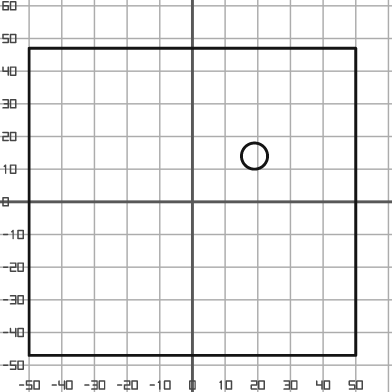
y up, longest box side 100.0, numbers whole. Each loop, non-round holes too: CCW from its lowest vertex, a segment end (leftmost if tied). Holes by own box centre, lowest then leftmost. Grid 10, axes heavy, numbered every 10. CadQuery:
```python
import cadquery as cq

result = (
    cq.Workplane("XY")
    .moveTo(-50.0, -47.0)
    .lineTo(50.0, -47.0)
    .lineTo(50.0, 47.0)
    .lineTo(-50.0, 47.0)
    .close()
    .moveTo(19.0, 14.0)
    .circle(4.0)
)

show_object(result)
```